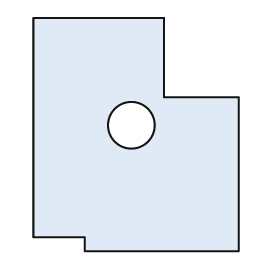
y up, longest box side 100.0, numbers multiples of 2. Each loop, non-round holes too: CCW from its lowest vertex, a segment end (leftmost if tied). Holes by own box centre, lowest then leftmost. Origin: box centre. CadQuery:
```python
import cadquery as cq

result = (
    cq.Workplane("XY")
    .moveTo(-22.0, -50.0)
    .lineTo(44.0, -50.0)
    .lineTo(44.0, 16.0)
    .lineTo(12.0, 16.0)
    .lineTo(12.0, 50.0)
    .lineTo(-44.0, 50.0)
    .lineTo(-44.0, -44.0)
    .lineTo(-22.0, -44.0)
    .close()
    .moveTo(-2.0, 4.0)
    .circle(10.0)
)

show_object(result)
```